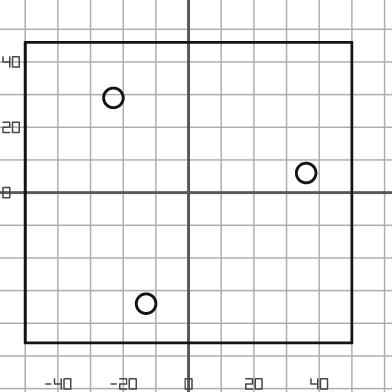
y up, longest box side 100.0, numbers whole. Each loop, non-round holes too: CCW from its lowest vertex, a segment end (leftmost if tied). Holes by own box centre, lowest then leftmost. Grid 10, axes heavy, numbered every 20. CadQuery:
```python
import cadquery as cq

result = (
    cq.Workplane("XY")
    .moveTo(-50.0, -46.0)
    .lineTo(50.0, -46.0)
    .lineTo(50.0, 46.0)
    .lineTo(-50.0, 46.0)
    .close()
    .moveTo(-13.0, -34.0)
    .circle(3.0)
    .moveTo(36.0, 6.0)
    .circle(3.0)
    .moveTo(-23.0, 29.0)
    .circle(3.0)
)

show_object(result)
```